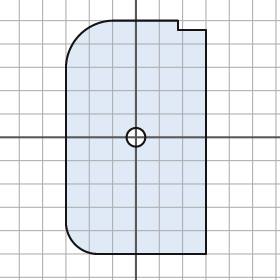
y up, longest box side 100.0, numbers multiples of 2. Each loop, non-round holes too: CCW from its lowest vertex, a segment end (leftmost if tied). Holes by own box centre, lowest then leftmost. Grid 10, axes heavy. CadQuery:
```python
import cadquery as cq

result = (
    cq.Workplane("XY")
    .moveTo(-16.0, -50.0)
    .lineTo(30.0, -50.0)
    .lineTo(30.0, 46.0)
    .lineTo(18.0, 46.0)
    .lineTo(18.0, 50.0)
    .lineTo(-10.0, 50.0)
    .threePointArc((-24.0, 44.0), (-30.0, 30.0))
    .lineTo(-30.0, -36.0)
    .threePointArc((-26.0, -46.0), (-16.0, -50.0))
    .close()
    .moveTo(0.0, 0.0)
    .circle(4.0)
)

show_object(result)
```